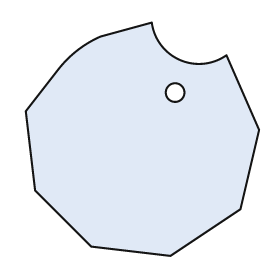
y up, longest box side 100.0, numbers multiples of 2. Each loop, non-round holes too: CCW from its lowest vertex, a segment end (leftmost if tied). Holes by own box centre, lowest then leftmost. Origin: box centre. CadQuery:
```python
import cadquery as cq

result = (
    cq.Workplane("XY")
    .moveTo(12.0, -50.0)
    .lineTo(42.0, -30.0)
    .lineTo(50.0, 4.0)
    .lineTo(36.0, 36.0)
    .threePointArc((16.0, 34.0), (4.0, 50.0))
    .lineTo(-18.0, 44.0)
    .threePointArc((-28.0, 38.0), (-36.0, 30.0))
    .lineTo(-50.0, 12.0)
    .lineTo(-46.0, -22.0)
    .lineTo(-22.0, -46.0)
    .close()
    .moveTo(14.0, 20.0)
    .circle(4.0)
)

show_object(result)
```